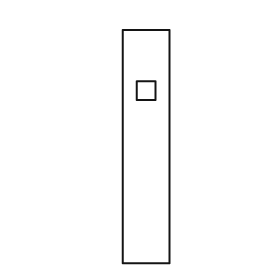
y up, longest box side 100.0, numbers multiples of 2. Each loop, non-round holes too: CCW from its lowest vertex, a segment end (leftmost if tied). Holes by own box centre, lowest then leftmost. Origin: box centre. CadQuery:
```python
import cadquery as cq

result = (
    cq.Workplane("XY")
    .moveTo(-10.0, -50.0)
    .lineTo(10.0, -50.0)
    .lineTo(10.0, 50.0)
    .lineTo(-10.0, 50.0)
    .close()
    .moveTo(-4.0, 20.0)
    .lineTo(4.0, 20.0)
    .lineTo(4.0, 28.0)
    .lineTo(-4.0, 28.0)
    .close()
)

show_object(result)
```